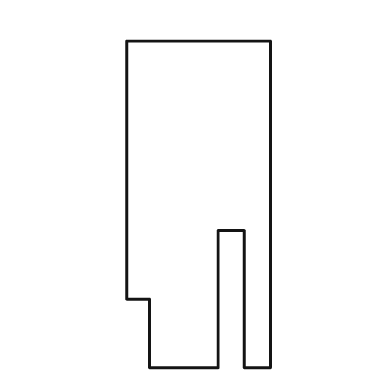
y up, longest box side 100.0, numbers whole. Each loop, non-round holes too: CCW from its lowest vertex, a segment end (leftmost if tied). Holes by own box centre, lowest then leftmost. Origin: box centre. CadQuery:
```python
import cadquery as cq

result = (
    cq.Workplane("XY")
    .moveTo(-15.0, -50.0)
    .lineTo(6.0, -50.0)
    .lineTo(6.0, -8.0)
    .lineTo(14.0, -8.0)
    .lineTo(14.0, -50.0)
    .lineTo(22.0, -50.0)
    .lineTo(22.0, 50.0)
    .lineTo(-22.0, 50.0)
    .lineTo(-22.0, -29.0)
    .lineTo(-15.0, -29.0)
    .close()
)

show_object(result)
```